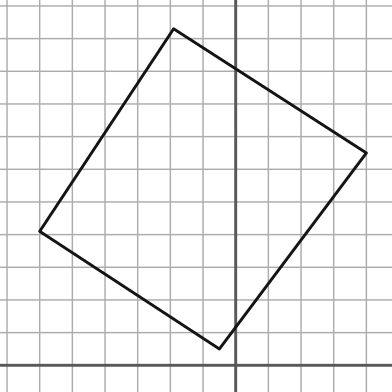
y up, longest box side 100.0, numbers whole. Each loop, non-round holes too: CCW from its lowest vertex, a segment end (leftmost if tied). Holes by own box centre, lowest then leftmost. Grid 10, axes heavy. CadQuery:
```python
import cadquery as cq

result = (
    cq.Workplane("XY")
    .moveTo(-5.0, 5.0)
    .lineTo(40.0, 65.0)
    .lineTo(-19.0, 103.0)
    .lineTo(-60.0, 41.0)
    .close()
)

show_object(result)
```